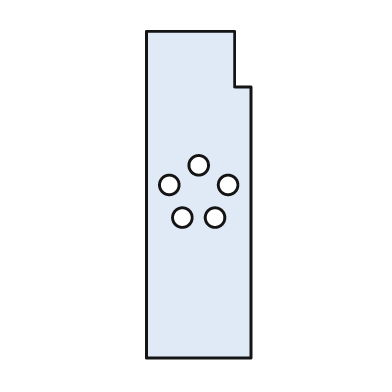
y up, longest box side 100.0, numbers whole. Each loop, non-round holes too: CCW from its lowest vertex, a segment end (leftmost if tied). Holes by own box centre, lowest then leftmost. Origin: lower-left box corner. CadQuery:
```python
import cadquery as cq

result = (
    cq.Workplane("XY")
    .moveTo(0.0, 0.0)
    .lineTo(32.0, 0.0)
    .lineTo(32.0, 83.0)
    .lineTo(27.0, 83.0)
    .lineTo(27.0, 100.0)
    .lineTo(0.0, 100.0)
    .close()
    .moveTo(11.0, 43.0)
    .circle(3.0)
    .moveTo(21.0, 43.0)
    .circle(3.0)
    .moveTo(7.0, 53.0)
    .circle(3.0)
    .moveTo(25.0, 53.0)
    .circle(3.0)
    .moveTo(16.0, 59.0)
    .circle(3.0)
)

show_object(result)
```